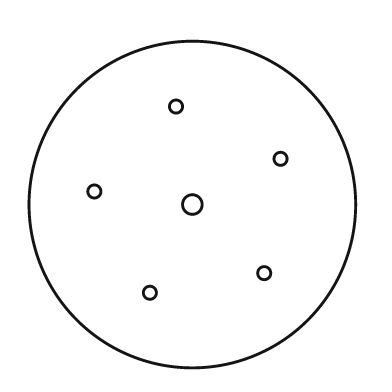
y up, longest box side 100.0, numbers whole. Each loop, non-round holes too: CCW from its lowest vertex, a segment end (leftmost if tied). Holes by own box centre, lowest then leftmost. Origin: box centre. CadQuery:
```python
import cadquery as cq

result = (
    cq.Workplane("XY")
    .moveTo(0.0, 0.0)
    .circle(50.0)
    .moveTo(-13.0, -27.0)
    .circle(2.0)
    .moveTo(22.0, -21.0)
    .circle(2.0)
    .moveTo(0.0, 0.0)
    .circle(3.0)
    .moveTo(-30.0, 4.0)
    .circle(2.0)
    .moveTo(27.0, 14.0)
    .circle(2.0)
    .moveTo(-5.0, 30.0)
    .circle(2.0)
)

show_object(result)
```